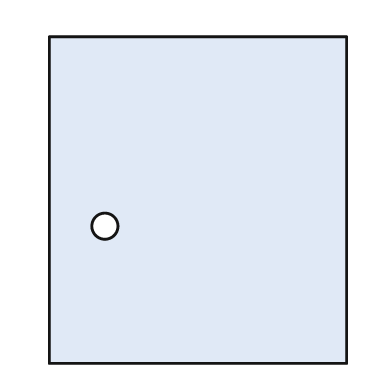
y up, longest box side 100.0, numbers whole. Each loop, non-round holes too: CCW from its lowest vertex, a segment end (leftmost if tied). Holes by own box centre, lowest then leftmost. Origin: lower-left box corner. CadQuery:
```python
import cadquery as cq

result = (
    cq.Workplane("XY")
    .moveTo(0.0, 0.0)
    .lineTo(91.0, 0.0)
    .lineTo(91.0, 100.0)
    .lineTo(0.0, 100.0)
    .close()
    .moveTo(17.0, 42.0)
    .circle(4.0)
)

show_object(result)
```